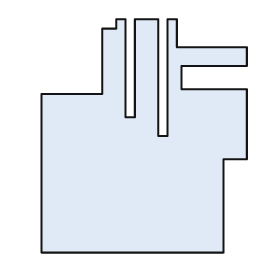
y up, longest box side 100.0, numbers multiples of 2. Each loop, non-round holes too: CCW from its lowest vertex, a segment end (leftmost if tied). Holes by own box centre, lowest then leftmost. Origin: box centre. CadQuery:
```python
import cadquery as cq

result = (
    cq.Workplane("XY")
    .moveTo(-44.0, -50.0)
    .lineTo(34.0, -50.0)
    .lineTo(34.0, -10.0)
    .lineTo(44.0, -10.0)
    .lineTo(44.0, 20.0)
    .lineTo(16.0, 20.0)
    .lineTo(16.0, 30.0)
    .lineTo(44.0, 30.0)
    .lineTo(44.0, 38.0)
    .lineTo(14.0, 38.0)
    .lineTo(14.0, 50.0)
    .lineTo(10.0, 50.0)
    .lineTo(10.0, 0.0)
    .lineTo(6.0, 0.0)
    .lineTo(6.0, 50.0)
    .lineTo(-4.0, 50.0)
    .lineTo(-4.0, 8.0)
    .lineTo(-8.0, 8.0)
    .lineTo(-8.0, 50.0)
    .lineTo(-12.0, 50.0)
    .lineTo(-12.0, 46.0)
    .lineTo(-18.0, 46.0)
    .lineTo(-18.0, 18.0)
    .lineTo(-44.0, 18.0)
    .close()
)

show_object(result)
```